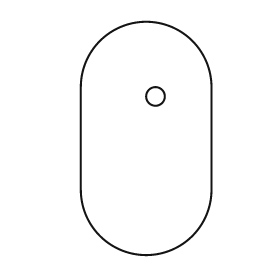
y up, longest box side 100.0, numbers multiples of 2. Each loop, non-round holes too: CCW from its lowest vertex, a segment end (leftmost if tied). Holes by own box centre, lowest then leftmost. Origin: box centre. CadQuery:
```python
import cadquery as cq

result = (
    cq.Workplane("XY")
    .moveTo(-28.0, -22.0)
    .threePointArc((0.0, -50.0), (28.0, -22.0))
    .lineTo(28.0, 22.0)
    .threePointArc((0.0, 50.0), (-28.0, 22.0))
    .close()
    .moveTo(4.0, 18.0)
    .circle(4.0)
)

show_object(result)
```